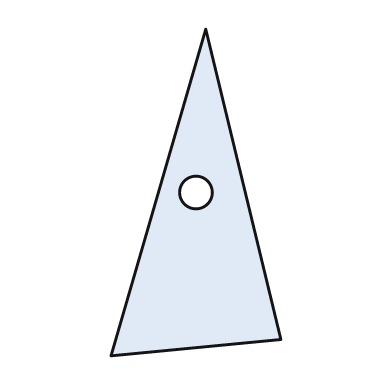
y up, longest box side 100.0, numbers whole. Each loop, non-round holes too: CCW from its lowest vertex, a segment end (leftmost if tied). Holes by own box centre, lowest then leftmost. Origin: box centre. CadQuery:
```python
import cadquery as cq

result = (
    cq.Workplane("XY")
    .moveTo(-26.0, -50.0)
    .lineTo(26.0, -45.0)
    .lineTo(3.0, 50.0)
    .close()
    .moveTo(0.0, 0.0)
    .circle(5.0)
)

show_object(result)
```